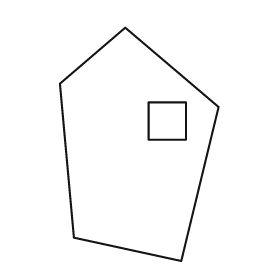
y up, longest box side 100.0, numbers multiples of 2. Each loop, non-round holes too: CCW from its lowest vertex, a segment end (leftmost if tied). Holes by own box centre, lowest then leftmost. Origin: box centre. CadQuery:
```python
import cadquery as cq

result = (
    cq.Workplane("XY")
    .moveTo(18.0, -50.0)
    .lineTo(34.0, 16.0)
    .lineTo(-6.0, 50.0)
    .lineTo(-34.0, 26.0)
    .lineTo(-28.0, -40.0)
    .close()
    .moveTo(4.0, 2.0)
    .lineTo(20.0, 2.0)
    .lineTo(20.0, 18.0)
    .lineTo(4.0, 18.0)
    .close()
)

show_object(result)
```